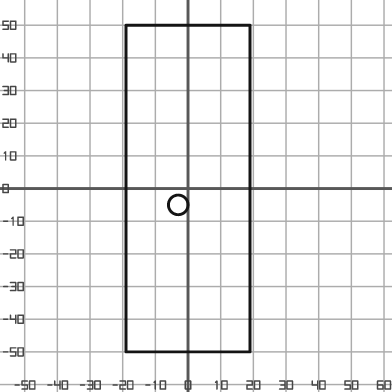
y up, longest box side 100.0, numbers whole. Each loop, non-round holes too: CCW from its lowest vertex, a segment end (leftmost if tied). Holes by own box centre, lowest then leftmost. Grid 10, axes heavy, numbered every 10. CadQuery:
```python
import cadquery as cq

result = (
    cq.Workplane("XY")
    .moveTo(-19.0, -50.0)
    .lineTo(19.0, -50.0)
    .lineTo(19.0, 50.0)
    .lineTo(-19.0, 50.0)
    .close()
    .moveTo(-3.0, -5.0)
    .circle(3.0)
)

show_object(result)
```